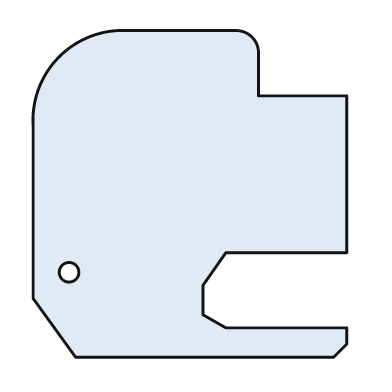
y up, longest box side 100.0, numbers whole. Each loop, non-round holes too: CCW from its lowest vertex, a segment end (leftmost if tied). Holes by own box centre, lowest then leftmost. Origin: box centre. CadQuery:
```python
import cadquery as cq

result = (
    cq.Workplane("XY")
    .moveTo(-35.0, -50.0)
    .lineTo(44.0, -50.0)
    .lineTo(48.0, -46.0)
    .lineTo(48.0, -41.0)
    .lineTo(11.0, -41.0)
    .lineTo(4.0, -37.0)
    .lineTo(4.0, -28.0)
    .lineTo(11.0, -18.0)
    .lineTo(48.0, -18.0)
    .lineTo(48.0, 30.0)
    .lineTo(21.0, 30.0)
    .lineTo(21.0, 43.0)
    .threePointArc((19.0, 48.0), (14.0, 50.0))
    .lineTo(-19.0, 50.0)
    .threePointArc((-40.0, 42.0), (-48.0, 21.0))
    .lineTo(-48.0, -32.0)
    .close()
    .moveTo(-37.0, -24.0)
    .circle(3.0)
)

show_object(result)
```